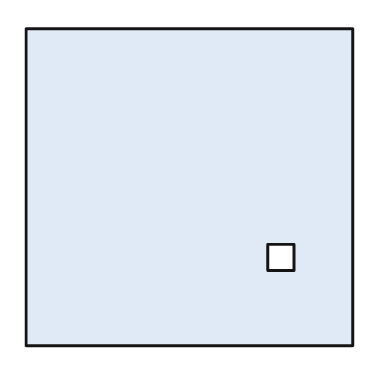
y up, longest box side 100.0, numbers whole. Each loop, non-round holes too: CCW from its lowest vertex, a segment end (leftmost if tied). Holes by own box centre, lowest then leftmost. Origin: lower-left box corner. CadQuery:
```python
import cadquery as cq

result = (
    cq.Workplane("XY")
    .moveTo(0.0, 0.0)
    .lineTo(100.0, 0.0)
    .lineTo(100.0, 97.0)
    .lineTo(0.0, 97.0)
    .close()
    .moveTo(74.0, 23.0)
    .lineTo(82.0, 23.0)
    .lineTo(82.0, 31.0)
    .lineTo(74.0, 31.0)
    .close()
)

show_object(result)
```